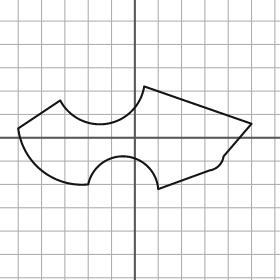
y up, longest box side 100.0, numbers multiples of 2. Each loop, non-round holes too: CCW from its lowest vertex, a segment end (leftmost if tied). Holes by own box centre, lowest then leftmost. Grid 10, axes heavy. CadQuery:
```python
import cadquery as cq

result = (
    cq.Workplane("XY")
    .moveTo(10.0, -22.0)
    .lineTo(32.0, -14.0)
    .threePointArc((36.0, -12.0), (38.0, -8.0))
    .lineTo(50.0, 6.0)
    .lineTo(4.0, 22.0)
    .threePointArc((-12.0, 6.0), (-32.0, 16.0))
    .lineTo(-50.0, 4.0)
    .threePointArc((-40.0, -14.0), (-20.0, -20.0))
    .threePointArc((-4.0, -8.0), (10.0, -22.0))
    .close()
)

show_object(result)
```